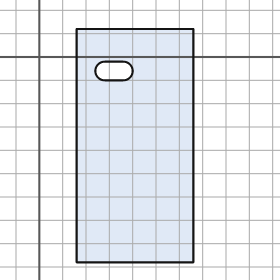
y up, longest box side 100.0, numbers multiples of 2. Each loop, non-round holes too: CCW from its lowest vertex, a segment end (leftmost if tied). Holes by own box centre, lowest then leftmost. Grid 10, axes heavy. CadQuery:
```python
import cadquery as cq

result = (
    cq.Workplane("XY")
    .moveTo(16.0, -88.0)
    .lineTo(66.0, -88.0)
    .lineTo(66.0, 12.0)
    .lineTo(16.0, 12.0)
    .close()
    .moveTo(28.0, -10.0)
    .lineTo(36.0, -10.0)
    .threePointArc((40.0, -6.0), (36.0, -2.0))
    .lineTo(28.0, -2.0)
    .threePointArc((24.0, -6.0), (28.0, -10.0))
    .close()
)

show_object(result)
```